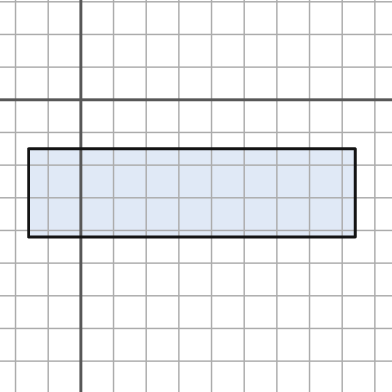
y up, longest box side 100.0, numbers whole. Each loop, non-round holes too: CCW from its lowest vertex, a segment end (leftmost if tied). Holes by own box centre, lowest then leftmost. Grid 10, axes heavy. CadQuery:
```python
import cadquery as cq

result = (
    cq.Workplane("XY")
    .moveTo(-16.0, -42.0)
    .lineTo(84.0, -42.0)
    .lineTo(84.0, -15.0)
    .lineTo(-16.0, -15.0)
    .close()
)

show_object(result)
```